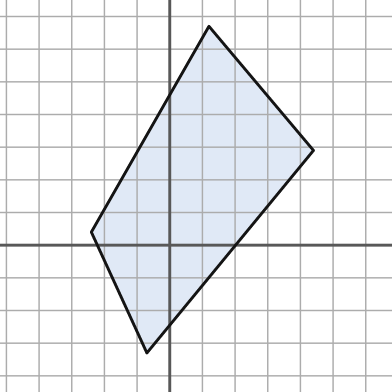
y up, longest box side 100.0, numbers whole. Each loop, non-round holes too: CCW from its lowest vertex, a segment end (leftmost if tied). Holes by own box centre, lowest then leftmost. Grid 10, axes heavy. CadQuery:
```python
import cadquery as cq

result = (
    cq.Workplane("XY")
    .moveTo(-7.0, -33.0)
    .lineTo(44.0, 29.0)
    .lineTo(12.0, 67.0)
    .lineTo(-24.0, 4.0)
    .close()
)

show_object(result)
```